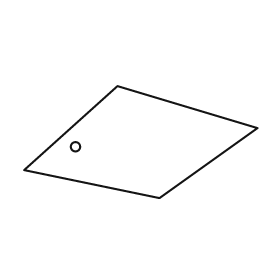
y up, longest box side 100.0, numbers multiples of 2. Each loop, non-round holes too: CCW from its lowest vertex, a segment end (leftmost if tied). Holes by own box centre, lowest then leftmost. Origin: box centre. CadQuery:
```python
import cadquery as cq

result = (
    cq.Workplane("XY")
    .moveTo(8.0, -24.0)
    .lineTo(50.0, 6.0)
    .lineTo(-10.0, 24.0)
    .lineTo(-50.0, -12.0)
    .close()
    .moveTo(-28.0, -2.0)
    .circle(2.0)
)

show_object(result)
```